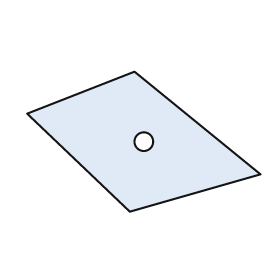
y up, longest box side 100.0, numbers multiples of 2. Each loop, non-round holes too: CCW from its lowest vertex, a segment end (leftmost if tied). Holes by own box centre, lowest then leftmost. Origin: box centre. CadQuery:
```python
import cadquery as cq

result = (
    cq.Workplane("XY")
    .moveTo(-6.0, -30.0)
    .lineTo(50.0, -14.0)
    .lineTo(-4.0, 30.0)
    .lineTo(-50.0, 12.0)
    .close()
    .moveTo(0.0, 0.0)
    .circle(4.0)
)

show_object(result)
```